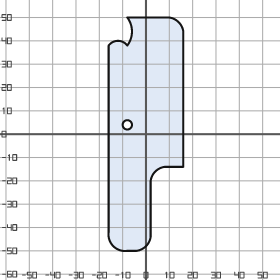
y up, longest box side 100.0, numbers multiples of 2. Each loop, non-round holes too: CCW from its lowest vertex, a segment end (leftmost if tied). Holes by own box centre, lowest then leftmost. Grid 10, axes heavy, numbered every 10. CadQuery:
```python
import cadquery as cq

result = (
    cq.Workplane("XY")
    .moveTo(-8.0, -50.0)
    .lineTo(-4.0, -50.0)
    .threePointArc((0.0, -48.0), (2.0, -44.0))
    .lineTo(2.0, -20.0)
    .threePointArc((4.0, -16.0), (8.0, -14.0))
    .lineTo(16.0, -14.0)
    .lineTo(16.0, 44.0)
    .threePointArc((14.0, 48.0), (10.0, 50.0))
    .lineTo(-8.0, 50.0)
    .threePointArc((-6.0, 44.0), (-8.0, 38.0))
    .threePointArc((-12.0, 40.0), (-16.0, 38.0))
    .lineTo(-16.0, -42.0)
    .threePointArc((-14.0, -48.0), (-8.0, -50.0))
    .close()
    .moveTo(-8.0, 4.0)
    .circle(2.0)
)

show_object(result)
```